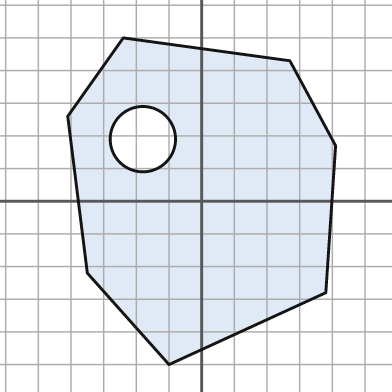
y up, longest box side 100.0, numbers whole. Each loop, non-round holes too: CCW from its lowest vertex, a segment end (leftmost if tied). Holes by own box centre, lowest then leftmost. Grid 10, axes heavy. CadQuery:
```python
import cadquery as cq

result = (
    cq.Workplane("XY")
    .moveTo(-10.0, -50.0)
    .lineTo(38.0, -28.0)
    .lineTo(41.0, 17.0)
    .lineTo(27.0, 43.0)
    .lineTo(-24.0, 50.0)
    .lineTo(-41.0, 26.0)
    .lineTo(-35.0, -22.0)
    .close()
    .moveTo(-18.0, 19.0)
    .circle(10.0)
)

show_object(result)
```